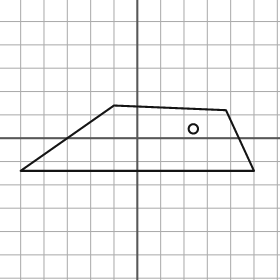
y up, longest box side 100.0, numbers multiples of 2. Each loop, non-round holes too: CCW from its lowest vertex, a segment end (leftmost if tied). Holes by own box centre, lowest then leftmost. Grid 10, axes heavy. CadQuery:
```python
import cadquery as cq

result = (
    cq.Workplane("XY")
    .moveTo(-50.0, -14.0)
    .lineTo(50.0, -14.0)
    .lineTo(38.0, 12.0)
    .lineTo(-10.0, 14.0)
    .close()
    .moveTo(24.0, 4.0)
    .circle(2.0)
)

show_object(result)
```